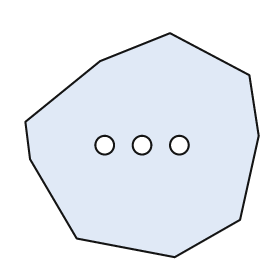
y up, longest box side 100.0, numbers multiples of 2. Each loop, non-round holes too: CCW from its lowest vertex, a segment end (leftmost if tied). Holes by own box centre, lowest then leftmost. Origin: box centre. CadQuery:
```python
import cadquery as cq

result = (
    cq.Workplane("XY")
    .moveTo(14.0, -48.0)
    .lineTo(42.0, -32.0)
    .lineTo(50.0, 4.0)
    .lineTo(46.0, 30.0)
    .lineTo(12.0, 48.0)
    .lineTo(-18.0, 36.0)
    .lineTo(-50.0, 10.0)
    .lineTo(-48.0, -6.0)
    .lineTo(-28.0, -40.0)
    .close()
    .moveTo(-16.0, 0.0)
    .circle(4.0)
    .moveTo(0.0, 0.0)
    .circle(4.0)
    .moveTo(16.0, 0.0)
    .circle(4.0)
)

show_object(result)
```